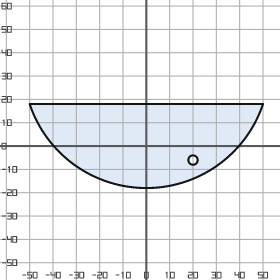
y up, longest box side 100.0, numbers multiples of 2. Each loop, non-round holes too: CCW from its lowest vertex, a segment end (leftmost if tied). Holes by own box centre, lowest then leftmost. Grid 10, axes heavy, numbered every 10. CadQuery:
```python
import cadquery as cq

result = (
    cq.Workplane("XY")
    .moveTo(-50.0, 18.0)
    .threePointArc((0.0, -18.0), (50.0, 18.0))
    .close()
    .moveTo(20.0, -6.0)
    .circle(2.0)
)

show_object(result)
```